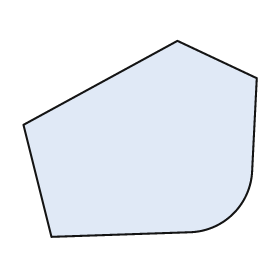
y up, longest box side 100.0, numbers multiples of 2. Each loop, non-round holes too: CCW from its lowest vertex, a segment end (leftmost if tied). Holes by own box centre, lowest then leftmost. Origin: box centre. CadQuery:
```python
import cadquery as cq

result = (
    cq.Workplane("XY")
    .moveTo(-38.0, -42.0)
    .lineTo(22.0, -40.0)
    .threePointArc((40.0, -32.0), (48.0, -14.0))
    .lineTo(50.0, 26.0)
    .lineTo(16.0, 42.0)
    .lineTo(-50.0, 6.0)
    .close()
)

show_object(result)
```